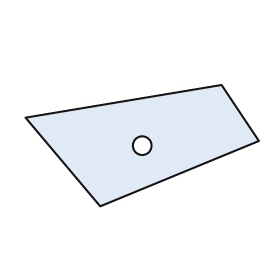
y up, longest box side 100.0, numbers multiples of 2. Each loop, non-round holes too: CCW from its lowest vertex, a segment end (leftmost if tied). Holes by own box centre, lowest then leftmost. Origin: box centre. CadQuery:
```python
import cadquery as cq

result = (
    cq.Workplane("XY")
    .moveTo(-18.0, -26.0)
    .lineTo(50.0, 2.0)
    .lineTo(34.0, 26.0)
    .lineTo(-50.0, 12.0)
    .close()
    .moveTo(0.0, 0.0)
    .circle(4.0)
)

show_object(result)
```